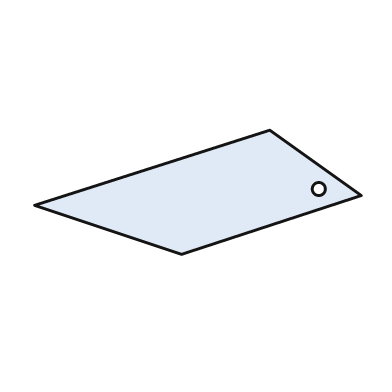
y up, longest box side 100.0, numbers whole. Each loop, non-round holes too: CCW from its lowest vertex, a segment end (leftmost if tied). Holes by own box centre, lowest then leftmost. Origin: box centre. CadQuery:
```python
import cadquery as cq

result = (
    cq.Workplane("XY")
    .moveTo(-5.0, -19.0)
    .lineTo(50.0, -1.0)
    .lineTo(22.0, 19.0)
    .lineTo(-50.0, -4.0)
    .close()
    .moveTo(37.0, 1.0)
    .circle(2.0)
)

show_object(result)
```